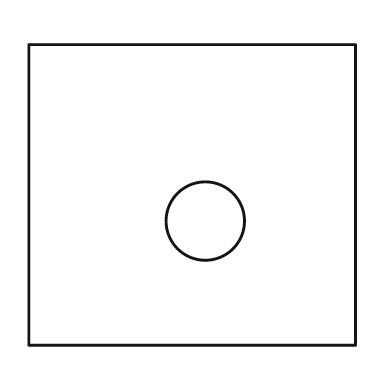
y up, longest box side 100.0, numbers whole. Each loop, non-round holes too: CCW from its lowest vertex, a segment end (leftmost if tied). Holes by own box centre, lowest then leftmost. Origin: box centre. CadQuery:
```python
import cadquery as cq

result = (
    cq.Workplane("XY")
    .moveTo(-50.0, -46.0)
    .lineTo(50.0, -46.0)
    .lineTo(50.0, 46.0)
    .lineTo(-50.0, 46.0)
    .close()
    .moveTo(4.0, -8.0)
    .circle(12.0)
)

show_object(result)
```